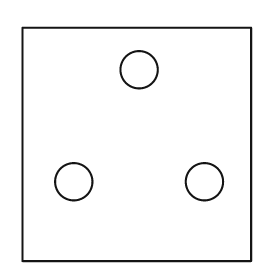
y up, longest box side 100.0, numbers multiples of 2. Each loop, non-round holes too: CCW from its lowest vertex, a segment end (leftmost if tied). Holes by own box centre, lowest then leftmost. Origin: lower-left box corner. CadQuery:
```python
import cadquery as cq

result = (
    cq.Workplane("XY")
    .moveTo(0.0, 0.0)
    .lineTo(98.0, 0.0)
    .lineTo(98.0, 100.0)
    .lineTo(0.0, 100.0)
    .close()
    .moveTo(22.0, 34.0)
    .circle(8.0)
    .moveTo(78.0, 34.0)
    .circle(8.0)
    .moveTo(50.0, 82.0)
    .circle(8.0)
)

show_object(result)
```